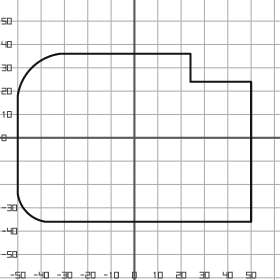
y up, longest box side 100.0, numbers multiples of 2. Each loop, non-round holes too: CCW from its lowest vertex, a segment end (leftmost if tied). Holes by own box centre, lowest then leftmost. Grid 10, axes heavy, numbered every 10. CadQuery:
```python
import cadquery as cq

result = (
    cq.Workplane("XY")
    .moveTo(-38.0, -36.0)
    .lineTo(50.0, -36.0)
    .lineTo(50.0, 24.0)
    .lineTo(24.0, 24.0)
    .lineTo(24.0, 36.0)
    .lineTo(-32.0, 36.0)
    .threePointArc((-44.0, 30.0), (-50.0, 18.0))
    .lineTo(-50.0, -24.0)
    .threePointArc((-46.0, -32.0), (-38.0, -36.0))
    .close()
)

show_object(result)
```